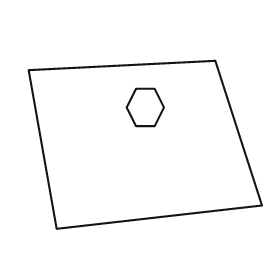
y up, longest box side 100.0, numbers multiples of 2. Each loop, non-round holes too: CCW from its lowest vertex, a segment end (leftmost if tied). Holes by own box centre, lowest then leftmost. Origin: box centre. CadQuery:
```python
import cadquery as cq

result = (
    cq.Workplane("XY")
    .moveTo(-38.0, -36.0)
    .lineTo(50.0, -26.0)
    .lineTo(30.0, 36.0)
    .lineTo(-50.0, 32.0)
    .close()
    .moveTo(-4.0, 8.0)
    .lineTo(4.0, 8.0)
    .lineTo(8.0, 16.0)
    .lineTo(4.0, 24.0)
    .lineTo(-4.0, 24.0)
    .lineTo(-8.0, 16.0)
    .close()
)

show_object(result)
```